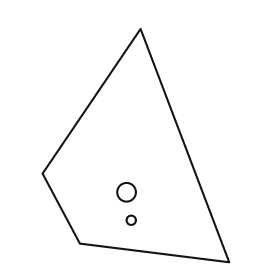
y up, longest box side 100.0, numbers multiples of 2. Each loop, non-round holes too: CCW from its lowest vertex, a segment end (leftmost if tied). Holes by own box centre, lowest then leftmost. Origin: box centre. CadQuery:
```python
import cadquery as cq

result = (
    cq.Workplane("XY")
    .moveTo(40.0, -50.0)
    .lineTo(2.0, 50.0)
    .lineTo(-40.0, -12.0)
    .lineTo(-24.0, -42.0)
    .close()
    .moveTo(-2.0, -32.0)
    .circle(2.0)
    .moveTo(-4.0, -20.0)
    .circle(4.0)
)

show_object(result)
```